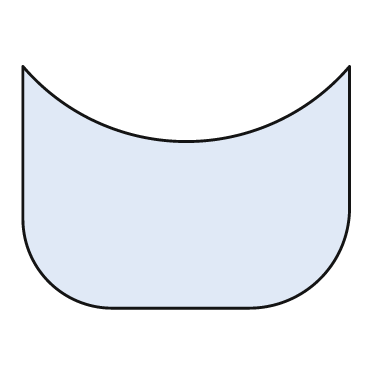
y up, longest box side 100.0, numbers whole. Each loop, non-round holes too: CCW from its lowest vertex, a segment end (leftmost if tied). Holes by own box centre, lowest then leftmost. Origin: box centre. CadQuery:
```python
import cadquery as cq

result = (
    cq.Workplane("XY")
    .moveTo(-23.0, -37.0)
    .lineTo(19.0, -37.0)
    .threePointArc((41.0, -28.0), (50.0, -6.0))
    .lineTo(50.0, 37.0)
    .threePointArc((0.0, 14.0), (-50.0, 37.0))
    .lineTo(-50.0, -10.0)
    .threePointArc((-42.0, -29.0), (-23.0, -37.0))
    .close()
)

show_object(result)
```